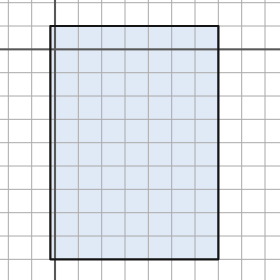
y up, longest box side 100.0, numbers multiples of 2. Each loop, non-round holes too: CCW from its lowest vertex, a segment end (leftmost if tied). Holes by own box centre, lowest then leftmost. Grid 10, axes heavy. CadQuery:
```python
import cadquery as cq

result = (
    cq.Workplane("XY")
    .moveTo(-2.0, -90.0)
    .lineTo(70.0, -90.0)
    .lineTo(70.0, 10.0)
    .lineTo(-2.0, 10.0)
    .close()
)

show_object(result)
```